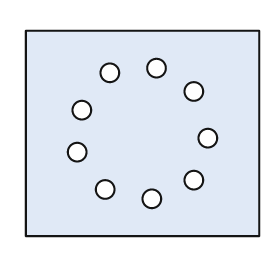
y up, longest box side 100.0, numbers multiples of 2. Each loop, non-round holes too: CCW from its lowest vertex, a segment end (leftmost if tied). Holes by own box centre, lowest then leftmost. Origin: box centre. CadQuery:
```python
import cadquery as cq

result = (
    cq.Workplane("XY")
    .moveTo(-50.0, -44.0)
    .lineTo(50.0, -44.0)
    .lineTo(50.0, 44.0)
    .lineTo(-50.0, 44.0)
    .close()
    .moveTo(4.0, -28.0)
    .circle(4.0)
    .moveTo(-16.0, -24.0)
    .circle(4.0)
    .moveTo(22.0, -20.0)
    .circle(4.0)
    .moveTo(-28.0, -8.0)
    .circle(4.0)
    .moveTo(28.0, -2.0)
    .circle(4.0)
    .moveTo(-26.0, 10.0)
    .circle(4.0)
    .moveTo(22.0, 18.0)
    .circle(4.0)
    .moveTo(-14.0, 26.0)
    .circle(4.0)
    .moveTo(6.0, 28.0)
    .circle(4.0)
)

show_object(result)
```